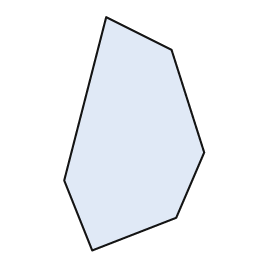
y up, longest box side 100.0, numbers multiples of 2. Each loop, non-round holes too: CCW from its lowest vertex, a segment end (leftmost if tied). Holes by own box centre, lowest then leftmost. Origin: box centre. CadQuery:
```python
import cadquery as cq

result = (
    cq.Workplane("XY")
    .moveTo(-18.0, -50.0)
    .lineTo(18.0, -36.0)
    .lineTo(30.0, -8.0)
    .lineTo(16.0, 36.0)
    .lineTo(-12.0, 50.0)
    .lineTo(-30.0, -20.0)
    .close()
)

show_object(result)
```